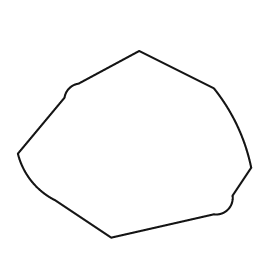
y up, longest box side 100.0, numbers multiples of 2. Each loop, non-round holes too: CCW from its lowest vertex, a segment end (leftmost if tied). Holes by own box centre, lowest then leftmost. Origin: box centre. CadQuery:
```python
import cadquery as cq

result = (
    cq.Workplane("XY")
    .moveTo(-10.0, -40.0)
    .lineTo(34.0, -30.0)
    .threePointArc((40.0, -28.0), (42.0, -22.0))
    .lineTo(50.0, -10.0)
    .threePointArc((44.0, 8.0), (34.0, 24.0))
    .lineTo(2.0, 40.0)
    .lineTo(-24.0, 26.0)
    .threePointArc((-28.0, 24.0), (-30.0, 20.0))
    .lineTo(-50.0, -4.0)
    .threePointArc((-44.0, -16.0), (-34.0, -24.0))
    .close()
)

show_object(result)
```